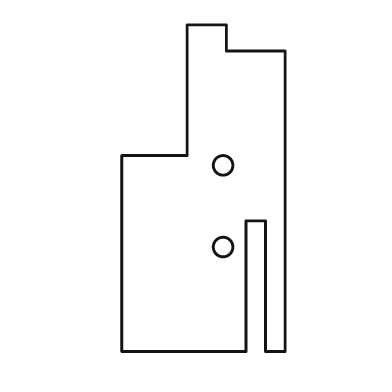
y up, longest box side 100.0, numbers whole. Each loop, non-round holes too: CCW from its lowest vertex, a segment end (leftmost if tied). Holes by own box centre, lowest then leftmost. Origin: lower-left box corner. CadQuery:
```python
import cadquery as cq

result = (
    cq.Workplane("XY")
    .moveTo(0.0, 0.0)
    .lineTo(38.0, 0.0)
    .lineTo(38.0, 40.0)
    .lineTo(44.0, 40.0)
    .lineTo(44.0, 0.0)
    .lineTo(50.0, 0.0)
    .lineTo(50.0, 92.0)
    .lineTo(32.0, 92.0)
    .lineTo(32.0, 100.0)
    .lineTo(20.0, 100.0)
    .lineTo(20.0, 60.0)
    .lineTo(0.0, 60.0)
    .close()
    .moveTo(31.0, 32.0)
    .circle(3.0)
    .moveTo(31.0, 57.0)
    .circle(3.0)
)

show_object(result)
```